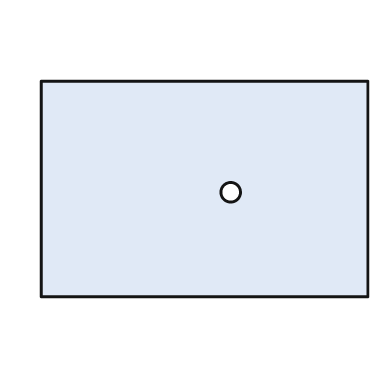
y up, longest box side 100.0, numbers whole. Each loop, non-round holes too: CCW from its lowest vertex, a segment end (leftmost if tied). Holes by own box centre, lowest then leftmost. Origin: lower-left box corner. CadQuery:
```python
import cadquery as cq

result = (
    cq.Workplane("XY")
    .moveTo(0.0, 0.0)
    .lineTo(100.0, 0.0)
    .lineTo(100.0, 66.0)
    .lineTo(0.0, 66.0)
    .close()
    .moveTo(58.0, 32.0)
    .circle(3.0)
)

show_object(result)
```